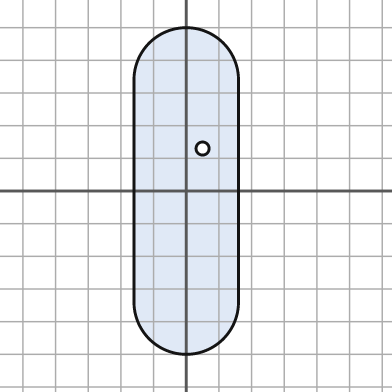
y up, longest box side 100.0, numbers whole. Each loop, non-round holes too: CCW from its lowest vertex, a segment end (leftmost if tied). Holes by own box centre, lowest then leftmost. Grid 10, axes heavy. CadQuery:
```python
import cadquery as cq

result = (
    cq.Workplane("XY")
    .moveTo(-16.0, -34.0)
    .threePointArc((0.0, -50.0), (16.0, -34.0))
    .lineTo(16.0, 34.0)
    .threePointArc((0.0, 50.0), (-16.0, 34.0))
    .close()
    .moveTo(5.0, 13.0)
    .circle(2.0)
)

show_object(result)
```